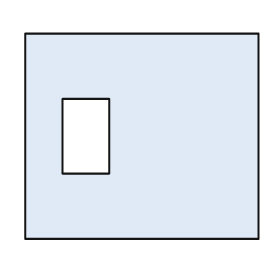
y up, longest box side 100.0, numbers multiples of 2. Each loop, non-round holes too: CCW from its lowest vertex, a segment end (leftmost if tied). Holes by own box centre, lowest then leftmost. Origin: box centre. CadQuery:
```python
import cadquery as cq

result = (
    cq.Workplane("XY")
    .moveTo(-50.0, -44.0)
    .lineTo(50.0, -44.0)
    .lineTo(50.0, 44.0)
    .lineTo(-50.0, 44.0)
    .close()
    .moveTo(-34.0, -16.0)
    .lineTo(-14.0, -16.0)
    .lineTo(-14.0, 16.0)
    .lineTo(-34.0, 16.0)
    .close()
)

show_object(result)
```